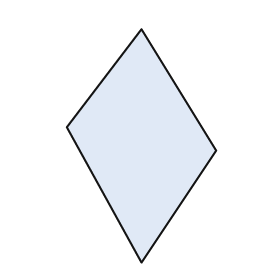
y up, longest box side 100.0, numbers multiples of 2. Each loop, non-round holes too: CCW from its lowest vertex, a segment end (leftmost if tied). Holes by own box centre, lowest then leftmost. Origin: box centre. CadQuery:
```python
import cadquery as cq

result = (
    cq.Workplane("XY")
    .moveTo(0.0, -50.0)
    .lineTo(32.0, -2.0)
    .lineTo(0.0, 50.0)
    .lineTo(-32.0, 8.0)
    .close()
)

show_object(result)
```